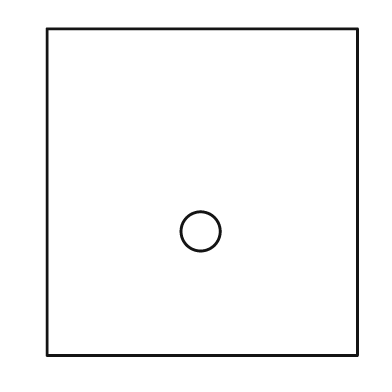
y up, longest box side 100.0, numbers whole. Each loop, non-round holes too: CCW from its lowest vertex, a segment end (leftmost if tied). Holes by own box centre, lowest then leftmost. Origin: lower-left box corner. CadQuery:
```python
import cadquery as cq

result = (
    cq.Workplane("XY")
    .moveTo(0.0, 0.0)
    .lineTo(95.0, 0.0)
    .lineTo(95.0, 100.0)
    .lineTo(0.0, 100.0)
    .close()
    .moveTo(47.0, 38.0)
    .circle(6.0)
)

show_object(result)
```